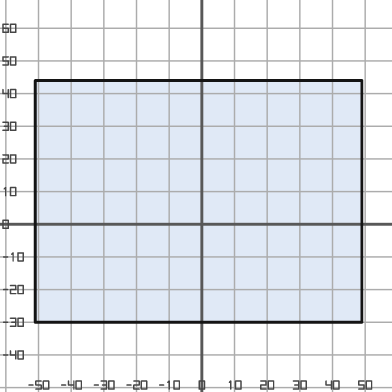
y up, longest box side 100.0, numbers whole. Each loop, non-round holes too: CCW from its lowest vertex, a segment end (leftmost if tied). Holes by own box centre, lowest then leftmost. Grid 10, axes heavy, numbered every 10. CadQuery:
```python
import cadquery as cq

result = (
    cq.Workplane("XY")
    .moveTo(-51.0, -30.0)
    .lineTo(49.0, -30.0)
    .lineTo(49.0, 44.0)
    .lineTo(-51.0, 44.0)
    .close()
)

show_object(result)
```